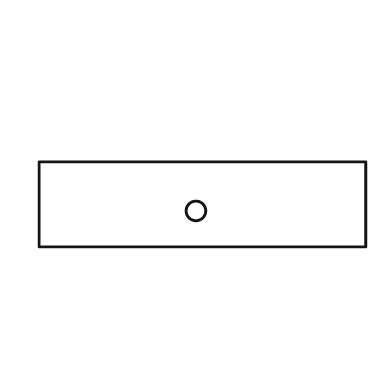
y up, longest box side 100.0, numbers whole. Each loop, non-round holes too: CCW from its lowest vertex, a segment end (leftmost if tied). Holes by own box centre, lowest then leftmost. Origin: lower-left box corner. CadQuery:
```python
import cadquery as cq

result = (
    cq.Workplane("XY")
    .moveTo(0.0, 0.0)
    .lineTo(100.0, 0.0)
    .lineTo(100.0, 26.0)
    .lineTo(0.0, 26.0)
    .close()
    .moveTo(48.0, 11.0)
    .circle(3.0)
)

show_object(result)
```